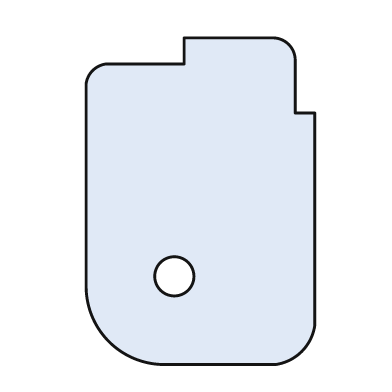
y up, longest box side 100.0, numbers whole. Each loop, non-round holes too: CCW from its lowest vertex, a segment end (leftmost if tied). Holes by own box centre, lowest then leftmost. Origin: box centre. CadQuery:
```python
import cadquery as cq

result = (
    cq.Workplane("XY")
    .moveTo(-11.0, -50.0)
    .lineTo(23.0, -50.0)
    .threePointArc((31.0, -46.0), (35.0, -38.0))
    .lineTo(35.0, 27.0)
    .lineTo(29.0, 27.0)
    .lineTo(29.0, 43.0)
    .threePointArc((27.0, 48.0), (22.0, 50.0))
    .lineTo(-5.0, 50.0)
    .lineTo(-5.0, 42.0)
    .lineTo(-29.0, 42.0)
    .threePointArc((-33.0, 40.0), (-35.0, 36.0))
    .lineTo(-35.0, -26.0)
    .threePointArc((-28.0, -43.0), (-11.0, -50.0))
    .close()
    .moveTo(-8.0, -23.0)
    .circle(6.0)
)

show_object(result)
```